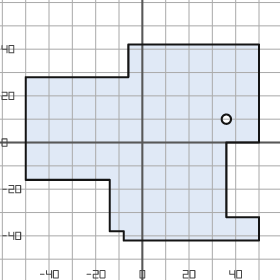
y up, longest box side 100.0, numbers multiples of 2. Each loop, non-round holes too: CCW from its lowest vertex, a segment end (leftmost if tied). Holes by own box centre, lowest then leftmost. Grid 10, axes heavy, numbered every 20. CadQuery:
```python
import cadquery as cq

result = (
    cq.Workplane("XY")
    .moveTo(-8.0, -42.0)
    .lineTo(50.0, -42.0)
    .lineTo(50.0, -32.0)
    .lineTo(36.0, -32.0)
    .lineTo(36.0, 0.0)
    .lineTo(50.0, 0.0)
    .lineTo(50.0, 42.0)
    .lineTo(-6.0, 42.0)
    .lineTo(-6.0, 28.0)
    .lineTo(-50.0, 28.0)
    .lineTo(-50.0, -16.0)
    .lineTo(-14.0, -16.0)
    .lineTo(-14.0, -38.0)
    .lineTo(-8.0, -38.0)
    .close()
    .moveTo(36.0, 10.0)
    .circle(2.0)
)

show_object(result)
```